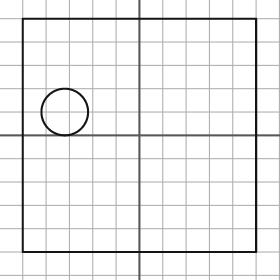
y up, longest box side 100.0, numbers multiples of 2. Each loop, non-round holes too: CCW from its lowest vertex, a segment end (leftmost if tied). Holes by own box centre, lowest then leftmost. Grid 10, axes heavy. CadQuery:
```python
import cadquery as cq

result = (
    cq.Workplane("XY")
    .moveTo(-50.0, -50.0)
    .lineTo(50.0, -50.0)
    .lineTo(50.0, 50.0)
    .lineTo(-50.0, 50.0)
    .close()
    .moveTo(-32.0, 10.0)
    .circle(10.0)
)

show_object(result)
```